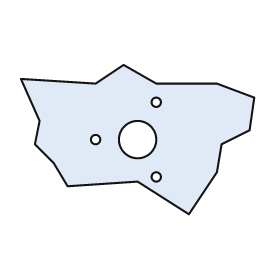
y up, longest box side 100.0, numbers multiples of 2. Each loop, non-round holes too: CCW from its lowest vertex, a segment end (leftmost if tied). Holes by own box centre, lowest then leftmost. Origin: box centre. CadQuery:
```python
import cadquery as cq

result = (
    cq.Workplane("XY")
    .moveTo(22.0, -32.0)
    .lineTo(34.0, -14.0)
    .lineTo(36.0, -2.0)
    .lineTo(48.0, 4.0)
    .lineTo(50.0, 18.0)
    .lineTo(34.0, 24.0)
    .lineTo(8.0, 24.0)
    .lineTo(-6.0, 32.0)
    .lineTo(-18.0, 24.0)
    .lineTo(-50.0, 26.0)
    .lineTo(-42.0, 8.0)
    .lineTo(-44.0, -2.0)
    .lineTo(-36.0, -10.0)
    .lineTo(-30.0, -20.0)
    .lineTo(0.0, -18.0)
    .close()
    .moveTo(8.0, -16.0)
    .circle(2.0)
    .moveTo(-18.0, 0.0)
    .circle(2.0)
    .moveTo(0.0, 0.0)
    .circle(8.0)
    .moveTo(8.0, 16.0)
    .circle(2.0)
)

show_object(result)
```